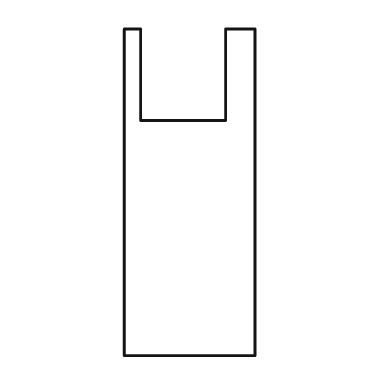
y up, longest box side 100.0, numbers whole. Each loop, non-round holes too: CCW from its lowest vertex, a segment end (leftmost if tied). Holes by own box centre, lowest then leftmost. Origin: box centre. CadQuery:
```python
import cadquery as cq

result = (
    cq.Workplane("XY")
    .moveTo(-20.0, -50.0)
    .lineTo(20.0, -50.0)
    .lineTo(20.0, 50.0)
    .lineTo(11.0, 50.0)
    .lineTo(11.0, 22.0)
    .lineTo(-15.0, 22.0)
    .lineTo(-15.0, 50.0)
    .lineTo(-20.0, 50.0)
    .close()
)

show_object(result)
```